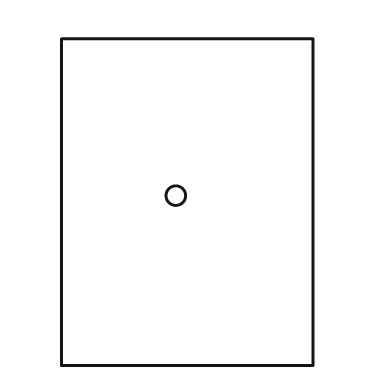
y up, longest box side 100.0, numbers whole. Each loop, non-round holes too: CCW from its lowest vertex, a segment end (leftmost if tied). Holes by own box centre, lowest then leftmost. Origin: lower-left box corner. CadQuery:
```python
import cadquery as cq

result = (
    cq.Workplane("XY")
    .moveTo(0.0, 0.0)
    .lineTo(77.0, 0.0)
    .lineTo(77.0, 100.0)
    .lineTo(0.0, 100.0)
    .close()
    .moveTo(35.0, 52.0)
    .circle(3.0)
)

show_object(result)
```